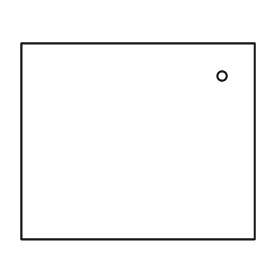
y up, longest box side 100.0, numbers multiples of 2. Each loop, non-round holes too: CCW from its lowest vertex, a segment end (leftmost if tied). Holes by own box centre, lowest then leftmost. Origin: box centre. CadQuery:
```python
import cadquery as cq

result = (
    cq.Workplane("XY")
    .moveTo(-50.0, -42.0)
    .lineTo(50.0, -42.0)
    .lineTo(50.0, 42.0)
    .lineTo(-50.0, 42.0)
    .close()
    .moveTo(36.0, 28.0)
    .circle(2.0)
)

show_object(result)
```